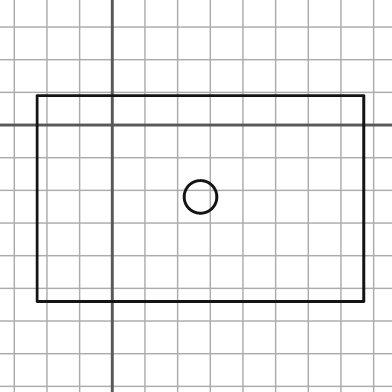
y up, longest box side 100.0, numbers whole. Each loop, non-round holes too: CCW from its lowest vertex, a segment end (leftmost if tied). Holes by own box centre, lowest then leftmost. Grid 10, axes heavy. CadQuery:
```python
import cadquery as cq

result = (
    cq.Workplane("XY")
    .moveTo(-23.0, -54.0)
    .lineTo(77.0, -54.0)
    .lineTo(77.0, 9.0)
    .lineTo(-23.0, 9.0)
    .close()
    .moveTo(27.0, -22.0)
    .circle(5.0)
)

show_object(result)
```